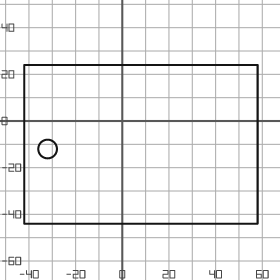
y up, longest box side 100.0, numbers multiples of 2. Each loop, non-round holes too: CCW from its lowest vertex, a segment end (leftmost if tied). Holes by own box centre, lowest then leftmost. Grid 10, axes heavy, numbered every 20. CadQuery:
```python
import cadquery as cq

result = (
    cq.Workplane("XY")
    .moveTo(-42.0, -44.0)
    .lineTo(58.0, -44.0)
    .lineTo(58.0, 24.0)
    .lineTo(-42.0, 24.0)
    .close()
    .moveTo(-32.0, -12.0)
    .circle(4.0)
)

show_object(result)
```